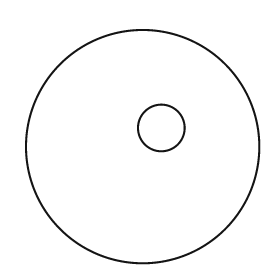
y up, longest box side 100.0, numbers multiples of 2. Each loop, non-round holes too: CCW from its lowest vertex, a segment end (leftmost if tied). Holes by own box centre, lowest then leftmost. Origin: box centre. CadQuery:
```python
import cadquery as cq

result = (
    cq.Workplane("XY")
    .moveTo(0.0, 0.0)
    .circle(50.0)
    .moveTo(8.0, 8.0)
    .circle(10.0)
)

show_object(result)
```